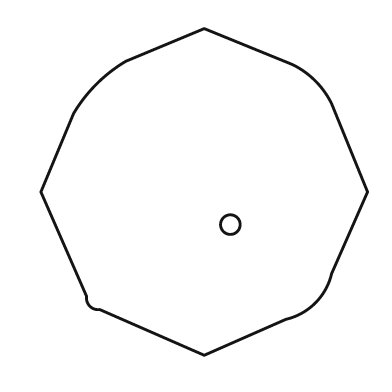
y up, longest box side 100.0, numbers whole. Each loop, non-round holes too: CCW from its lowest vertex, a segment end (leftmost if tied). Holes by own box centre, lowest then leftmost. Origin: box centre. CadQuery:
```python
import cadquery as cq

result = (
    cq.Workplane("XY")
    .moveTo(0.0, -50.0)
    .lineTo(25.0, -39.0)
    .threePointArc((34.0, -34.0), (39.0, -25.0))
    .lineTo(50.0, 0.0)
    .lineTo(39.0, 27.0)
    .threePointArc((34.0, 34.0), (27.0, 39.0))
    .lineTo(0.0, 50.0)
    .lineTo(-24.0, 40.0)
    .threePointArc((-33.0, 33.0), (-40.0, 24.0))
    .lineTo(-50.0, 0.0)
    .lineTo(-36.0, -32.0)
    .threePointArc((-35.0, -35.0), (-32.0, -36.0))
    .close()
    .moveTo(8.0, -10.0)
    .circle(3.0)
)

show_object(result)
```